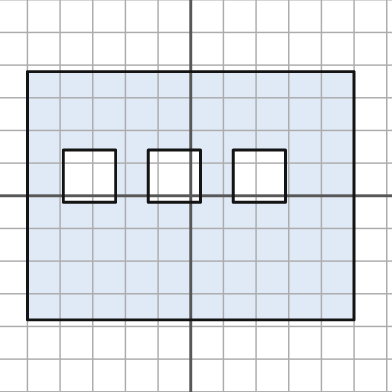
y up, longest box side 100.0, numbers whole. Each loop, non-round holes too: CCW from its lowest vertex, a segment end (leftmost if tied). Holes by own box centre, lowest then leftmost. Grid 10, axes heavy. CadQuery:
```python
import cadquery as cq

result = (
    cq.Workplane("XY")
    .moveTo(-50.0, -38.0)
    .lineTo(50.0, -38.0)
    .lineTo(50.0, 38.0)
    .lineTo(-50.0, 38.0)
    .close()
    .moveTo(-39.0, -2.0)
    .lineTo(-23.0, -2.0)
    .lineTo(-23.0, 14.0)
    .lineTo(-39.0, 14.0)
    .close()
    .moveTo(-13.0, -2.0)
    .lineTo(3.0, -2.0)
    .lineTo(3.0, 14.0)
    .lineTo(-13.0, 14.0)
    .close()
    .moveTo(13.0, -2.0)
    .lineTo(29.0, -2.0)
    .lineTo(29.0, 14.0)
    .lineTo(13.0, 14.0)
    .close()
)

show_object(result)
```